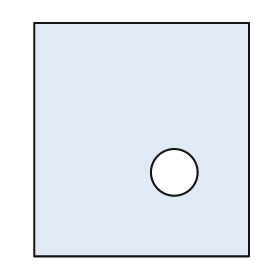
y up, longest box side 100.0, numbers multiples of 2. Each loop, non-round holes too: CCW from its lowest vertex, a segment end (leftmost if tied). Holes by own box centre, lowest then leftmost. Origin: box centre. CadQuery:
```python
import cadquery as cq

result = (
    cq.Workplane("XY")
    .moveTo(-46.0, -50.0)
    .lineTo(46.0, -50.0)
    .lineTo(46.0, 50.0)
    .lineTo(-46.0, 50.0)
    .close()
    .moveTo(14.0, -14.0)
    .circle(10.0)
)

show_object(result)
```